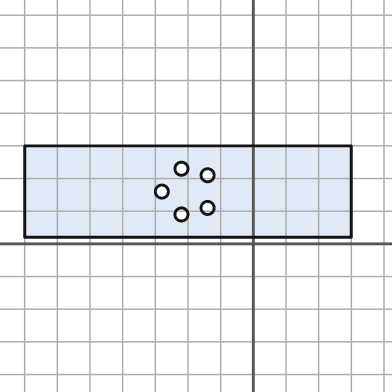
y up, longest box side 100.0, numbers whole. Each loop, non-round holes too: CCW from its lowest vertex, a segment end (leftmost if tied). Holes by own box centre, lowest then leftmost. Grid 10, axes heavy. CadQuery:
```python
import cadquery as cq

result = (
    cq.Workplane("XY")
    .moveTo(-70.0, 2.0)
    .lineTo(30.0, 2.0)
    .lineTo(30.0, 30.0)
    .lineTo(-70.0, 30.0)
    .close()
    .moveTo(-22.0, 9.0)
    .circle(2.0)
    .moveTo(-14.0, 11.0)
    .circle(2.0)
    .moveTo(-28.0, 16.0)
    .circle(2.0)
    .moveTo(-14.0, 21.0)
    .circle(2.0)
    .moveTo(-22.0, 23.0)
    .circle(2.0)
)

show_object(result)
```